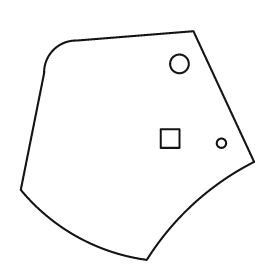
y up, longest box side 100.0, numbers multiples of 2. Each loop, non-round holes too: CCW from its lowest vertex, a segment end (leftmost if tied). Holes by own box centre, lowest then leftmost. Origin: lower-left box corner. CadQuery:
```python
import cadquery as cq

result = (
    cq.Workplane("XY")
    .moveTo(54.0, 0.0)
    .threePointArc((74.0, 24.0), (100.0, 42.0))
    .lineTo(74.0, 98.0)
    .lineTo(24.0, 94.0)
    .threePointArc((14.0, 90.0), (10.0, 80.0))
    .lineTo(0.0, 30.0)
    .threePointArc((24.0, 10.0), (54.0, 0.0))
    .close()
    .moveTo(86.0, 50.0)
    .circle(2.0)
    .moveTo(60.0, 48.0)
    .lineTo(68.0, 48.0)
    .lineTo(68.0, 56.0)
    .lineTo(60.0, 56.0)
    .close()
    .moveTo(68.0, 84.0)
    .circle(4.0)
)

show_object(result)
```